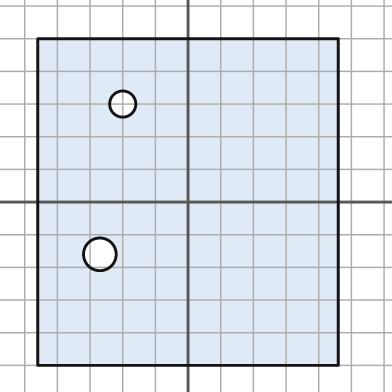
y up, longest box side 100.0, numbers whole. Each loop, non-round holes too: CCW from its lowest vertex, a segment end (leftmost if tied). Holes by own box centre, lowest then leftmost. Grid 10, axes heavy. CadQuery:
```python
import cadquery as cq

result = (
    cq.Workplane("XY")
    .moveTo(-46.0, -50.0)
    .lineTo(46.0, -50.0)
    .lineTo(46.0, 50.0)
    .lineTo(-46.0, 50.0)
    .close()
    .moveTo(-27.0, -16.0)
    .circle(5.0)
    .moveTo(-20.0, 30.0)
    .circle(4.0)
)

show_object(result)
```